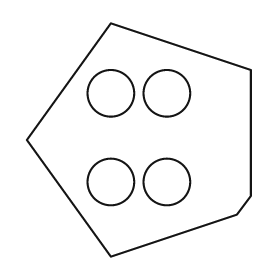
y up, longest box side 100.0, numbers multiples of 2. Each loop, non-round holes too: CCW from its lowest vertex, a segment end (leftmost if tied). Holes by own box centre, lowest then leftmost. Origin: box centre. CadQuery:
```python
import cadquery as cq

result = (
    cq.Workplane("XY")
    .moveTo(-12.0, -50.0)
    .lineTo(42.0, -32.0)
    .lineTo(48.0, -24.0)
    .lineTo(48.0, 30.0)
    .lineTo(-12.0, 50.0)
    .lineTo(-48.0, 0.0)
    .close()
    .moveTo(-12.0, -18.0)
    .circle(10.0)
    .moveTo(12.0, -18.0)
    .circle(10.0)
    .moveTo(-12.0, 20.0)
    .circle(10.0)
    .moveTo(12.0, 20.0)
    .circle(10.0)
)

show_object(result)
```